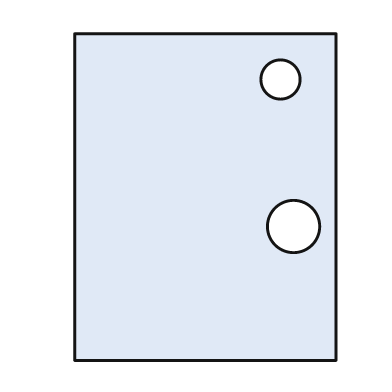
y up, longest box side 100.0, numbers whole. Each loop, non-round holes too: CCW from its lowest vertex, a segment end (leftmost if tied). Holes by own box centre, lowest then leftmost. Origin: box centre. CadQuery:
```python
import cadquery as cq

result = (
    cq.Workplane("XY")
    .moveTo(-40.0, -50.0)
    .lineTo(40.0, -50.0)
    .lineTo(40.0, 50.0)
    .lineTo(-40.0, 50.0)
    .close()
    .moveTo(27.0, -9.0)
    .circle(8.0)
    .moveTo(23.0, 36.0)
    .circle(6.0)
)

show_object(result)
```